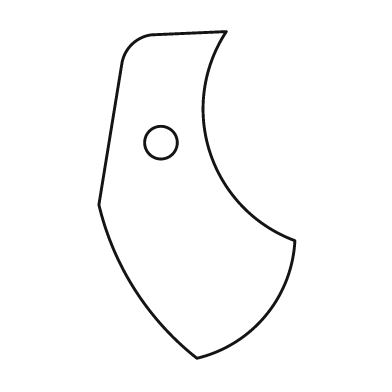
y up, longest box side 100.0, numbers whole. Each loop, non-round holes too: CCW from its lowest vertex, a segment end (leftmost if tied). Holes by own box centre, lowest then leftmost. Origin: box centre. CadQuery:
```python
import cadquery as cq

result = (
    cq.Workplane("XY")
    .moveTo(0.0, -50.0)
    .threePointArc((21.0, -37.0), (30.0, -14.0))
    .threePointArc((4.0, 13.0), (9.0, 50.0))
    .lineTo(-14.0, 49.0)
    .threePointArc((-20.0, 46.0), (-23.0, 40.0))
    .lineTo(-30.0, -3.0)
    .threePointArc((-19.0, -29.0), (0.0, -50.0))
    .close()
    .moveTo(-11.0, 16.0)
    .circle(5.0)
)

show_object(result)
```